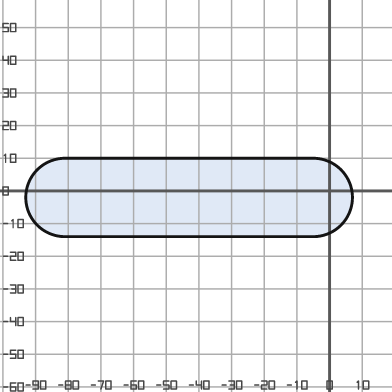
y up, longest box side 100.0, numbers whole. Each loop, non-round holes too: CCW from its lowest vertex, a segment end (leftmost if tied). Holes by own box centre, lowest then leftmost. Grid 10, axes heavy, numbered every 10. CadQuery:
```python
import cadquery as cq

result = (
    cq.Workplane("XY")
    .moveTo(-81.0, -14.0)
    .lineTo(-5.0, -14.0)
    .threePointArc((7.0, -2.0), (-5.0, 10.0))
    .lineTo(-81.0, 10.0)
    .threePointArc((-93.0, -2.0), (-81.0, -14.0))
    .close()
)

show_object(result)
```